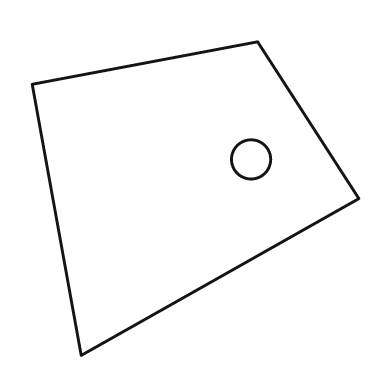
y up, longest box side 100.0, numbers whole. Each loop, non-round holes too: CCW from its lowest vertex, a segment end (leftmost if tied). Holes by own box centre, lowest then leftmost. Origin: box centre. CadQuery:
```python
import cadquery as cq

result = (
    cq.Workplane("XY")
    .moveTo(-35.0, -48.0)
    .lineTo(50.0, 0.0)
    .lineTo(19.0, 48.0)
    .lineTo(-50.0, 35.0)
    .close()
    .moveTo(17.0, 12.0)
    .circle(6.0)
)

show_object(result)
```